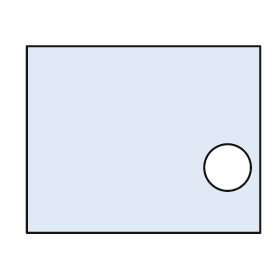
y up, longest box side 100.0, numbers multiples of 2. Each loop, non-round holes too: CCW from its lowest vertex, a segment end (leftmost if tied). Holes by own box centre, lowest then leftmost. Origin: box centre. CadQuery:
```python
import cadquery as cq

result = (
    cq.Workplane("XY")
    .moveTo(-50.0, -40.0)
    .lineTo(50.0, -40.0)
    .lineTo(50.0, 40.0)
    .lineTo(-50.0, 40.0)
    .close()
    .moveTo(36.0, -12.0)
    .circle(10.0)
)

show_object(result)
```